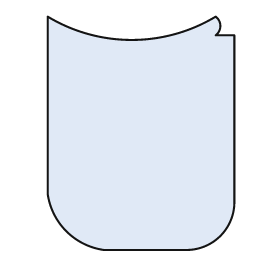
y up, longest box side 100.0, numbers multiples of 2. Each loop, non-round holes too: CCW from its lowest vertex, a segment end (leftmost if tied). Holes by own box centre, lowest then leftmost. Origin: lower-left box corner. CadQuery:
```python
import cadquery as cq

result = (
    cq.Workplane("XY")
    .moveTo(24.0, 0.0)
    .lineTo(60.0, 0.0)
    .threePointArc((74.0, 6.0), (80.0, 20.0))
    .lineTo(80.0, 92.0)
    .lineTo(72.0, 92.0)
    .threePointArc((74.0, 96.0), (72.0, 100.0))
    .threePointArc((36.0, 90.0), (0.0, 100.0))
    .lineTo(0.0, 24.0)
    .threePointArc((8.0, 8.0), (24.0, 0.0))
    .close()
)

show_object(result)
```